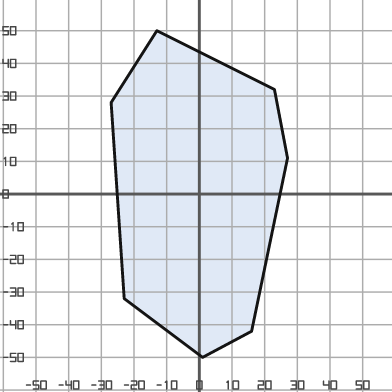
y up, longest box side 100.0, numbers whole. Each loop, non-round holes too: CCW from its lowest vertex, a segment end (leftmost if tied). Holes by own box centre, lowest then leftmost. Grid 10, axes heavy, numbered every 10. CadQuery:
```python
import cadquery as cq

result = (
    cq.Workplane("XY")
    .moveTo(1.0, -50.0)
    .lineTo(16.0, -42.0)
    .lineTo(27.0, 11.0)
    .lineTo(23.0, 32.0)
    .lineTo(-13.0, 50.0)
    .lineTo(-27.0, 28.0)
    .lineTo(-23.0, -32.0)
    .close()
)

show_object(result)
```